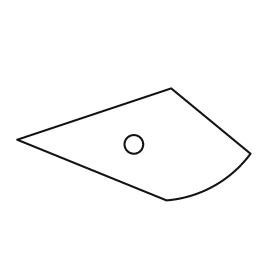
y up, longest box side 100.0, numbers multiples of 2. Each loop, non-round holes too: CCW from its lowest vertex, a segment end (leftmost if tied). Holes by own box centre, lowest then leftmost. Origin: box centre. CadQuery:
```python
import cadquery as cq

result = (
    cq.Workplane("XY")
    .moveTo(14.0, -24.0)
    .threePointArc((34.0, -18.0), (50.0, -4.0))
    .lineTo(16.0, 24.0)
    .lineTo(-50.0, 2.0)
    .close()
    .moveTo(0.0, 0.0)
    .circle(4.0)
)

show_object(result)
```